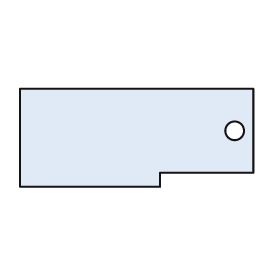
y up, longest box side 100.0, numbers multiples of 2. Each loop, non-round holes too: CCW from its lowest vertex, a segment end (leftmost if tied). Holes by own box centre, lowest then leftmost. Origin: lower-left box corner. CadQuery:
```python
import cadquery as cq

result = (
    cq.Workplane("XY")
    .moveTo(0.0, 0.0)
    .lineTo(60.0, 0.0)
    .lineTo(60.0, 6.0)
    .lineTo(100.0, 6.0)
    .lineTo(100.0, 42.0)
    .lineTo(0.0, 42.0)
    .close()
    .moveTo(92.0, 24.0)
    .circle(4.0)
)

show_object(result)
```